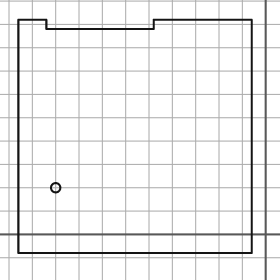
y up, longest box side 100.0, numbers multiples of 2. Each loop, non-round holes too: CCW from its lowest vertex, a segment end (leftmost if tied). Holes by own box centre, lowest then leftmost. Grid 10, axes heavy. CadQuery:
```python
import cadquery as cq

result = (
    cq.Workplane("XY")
    .moveTo(-106.0, -8.0)
    .lineTo(-6.0, -8.0)
    .lineTo(-6.0, 92.0)
    .lineTo(-48.0, 92.0)
    .lineTo(-48.0, 88.0)
    .lineTo(-94.0, 88.0)
    .lineTo(-94.0, 92.0)
    .lineTo(-106.0, 92.0)
    .close()
    .moveTo(-90.0, 20.0)
    .circle(2.0)
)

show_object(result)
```